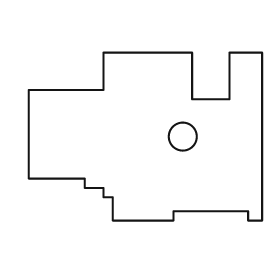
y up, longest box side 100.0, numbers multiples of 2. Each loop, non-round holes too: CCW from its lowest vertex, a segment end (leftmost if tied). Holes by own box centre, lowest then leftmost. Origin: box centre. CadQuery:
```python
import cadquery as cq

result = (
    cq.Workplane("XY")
    .moveTo(-14.0, -36.0)
    .lineTo(12.0, -36.0)
    .lineTo(12.0, -32.0)
    .lineTo(44.0, -32.0)
    .lineTo(44.0, -36.0)
    .lineTo(50.0, -36.0)
    .lineTo(50.0, 36.0)
    .lineTo(36.0, 36.0)
    .lineTo(36.0, 16.0)
    .lineTo(20.0, 16.0)
    .lineTo(20.0, 36.0)
    .lineTo(-18.0, 36.0)
    .lineTo(-18.0, 20.0)
    .lineTo(-50.0, 20.0)
    .lineTo(-50.0, -18.0)
    .lineTo(-26.0, -18.0)
    .lineTo(-26.0, -22.0)
    .lineTo(-18.0, -22.0)
    .lineTo(-18.0, -26.0)
    .lineTo(-14.0, -26.0)
    .close()
    .moveTo(16.0, 0.0)
    .circle(6.0)
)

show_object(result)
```